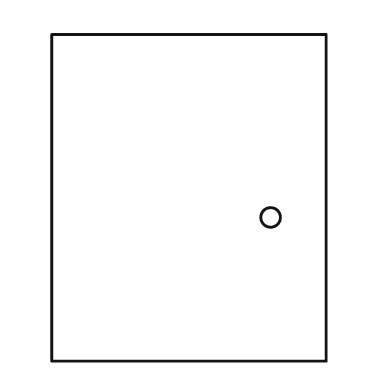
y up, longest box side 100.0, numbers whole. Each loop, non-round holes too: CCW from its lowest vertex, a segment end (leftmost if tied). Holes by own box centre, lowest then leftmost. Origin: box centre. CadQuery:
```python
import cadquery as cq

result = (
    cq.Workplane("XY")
    .moveTo(-42.0, -50.0)
    .lineTo(42.0, -50.0)
    .lineTo(42.0, 50.0)
    .lineTo(-42.0, 50.0)
    .close()
    .moveTo(25.0, -6.0)
    .circle(3.0)
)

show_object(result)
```